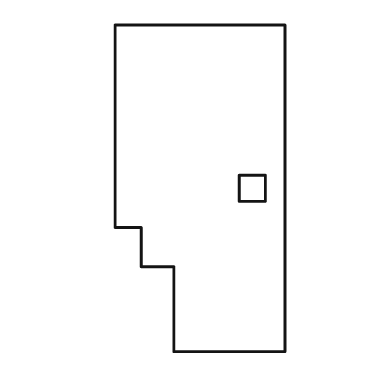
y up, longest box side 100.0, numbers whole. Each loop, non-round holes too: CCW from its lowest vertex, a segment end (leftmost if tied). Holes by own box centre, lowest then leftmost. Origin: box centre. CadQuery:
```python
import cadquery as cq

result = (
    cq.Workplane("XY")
    .moveTo(-8.0, -50.0)
    .lineTo(26.0, -50.0)
    .lineTo(26.0, 50.0)
    .lineTo(-26.0, 50.0)
    .lineTo(-26.0, -12.0)
    .lineTo(-18.0, -12.0)
    .lineTo(-18.0, -24.0)
    .lineTo(-8.0, -24.0)
    .close()
    .moveTo(12.0, -4.0)
    .lineTo(20.0, -4.0)
    .lineTo(20.0, 4.0)
    .lineTo(12.0, 4.0)
    .close()
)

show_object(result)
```